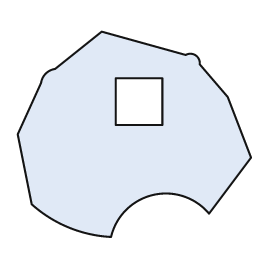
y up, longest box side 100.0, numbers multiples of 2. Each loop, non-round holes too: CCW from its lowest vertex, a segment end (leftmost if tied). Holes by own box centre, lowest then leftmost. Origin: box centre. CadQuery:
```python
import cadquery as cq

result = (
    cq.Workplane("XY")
    .moveTo(-10.0, -44.0)
    .threePointArc((8.0, -26.0), (32.0, -34.0))
    .lineTo(50.0, -10.0)
    .lineTo(40.0, 16.0)
    .lineTo(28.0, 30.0)
    .threePointArc((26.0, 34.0), (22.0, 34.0))
    .lineTo(-14.0, 44.0)
    .lineTo(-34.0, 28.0)
    .threePointArc((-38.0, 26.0), (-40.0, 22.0))
    .lineTo(-50.0, 0.0)
    .lineTo(-44.0, -30.0)
    .threePointArc((-28.0, -40.0), (-10.0, -44.0))
    .close()
    .moveTo(-8.0, 4.0)
    .lineTo(12.0, 4.0)
    .lineTo(12.0, 24.0)
    .lineTo(-8.0, 24.0)
    .close()
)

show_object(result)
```